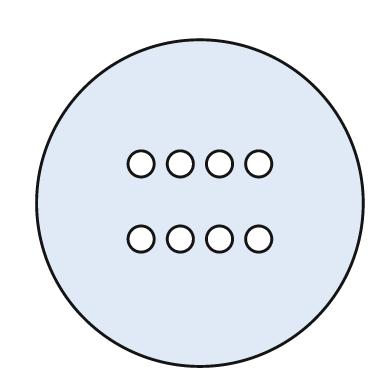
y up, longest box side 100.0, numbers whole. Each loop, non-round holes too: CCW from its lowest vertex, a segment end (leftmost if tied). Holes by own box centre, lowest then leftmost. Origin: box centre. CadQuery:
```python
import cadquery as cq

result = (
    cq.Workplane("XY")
    .moveTo(0.0, 0.0)
    .circle(50.0)
    .moveTo(-18.0, -11.0)
    .circle(4.0)
    .moveTo(-6.0, -11.0)
    .circle(4.0)
    .moveTo(6.0, -11.0)
    .circle(4.0)
    .moveTo(18.0, -11.0)
    .circle(4.0)
    .moveTo(-18.0, 12.0)
    .circle(4.0)
    .moveTo(-6.0, 12.0)
    .circle(4.0)
    .moveTo(6.0, 12.0)
    .circle(4.0)
    .moveTo(18.0, 12.0)
    .circle(4.0)
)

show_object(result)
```